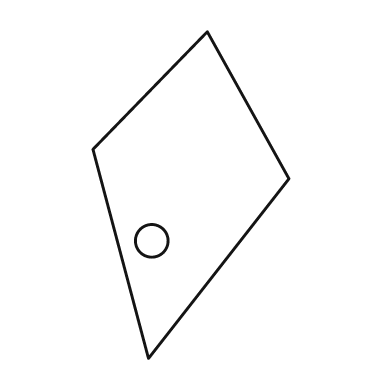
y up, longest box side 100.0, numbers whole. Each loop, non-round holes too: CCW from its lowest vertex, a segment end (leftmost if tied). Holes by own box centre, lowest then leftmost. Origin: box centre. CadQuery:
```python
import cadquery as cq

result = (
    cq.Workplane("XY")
    .moveTo(-13.0, -50.0)
    .lineTo(30.0, 5.0)
    .lineTo(5.0, 50.0)
    .lineTo(-30.0, 14.0)
    .close()
    .moveTo(-12.0, -14.0)
    .circle(5.0)
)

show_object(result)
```